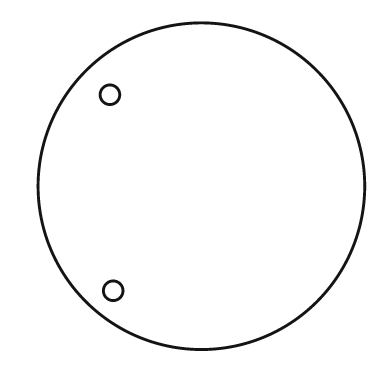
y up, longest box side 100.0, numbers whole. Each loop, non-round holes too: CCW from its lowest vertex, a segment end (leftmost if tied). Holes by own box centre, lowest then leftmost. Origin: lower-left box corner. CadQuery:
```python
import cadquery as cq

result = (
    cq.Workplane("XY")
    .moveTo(50.0, 50.0)
    .circle(50.0)
    .moveTo(23.0, 18.0)
    .circle(3.0)
    .moveTo(22.0, 78.0)
    .circle(3.0)
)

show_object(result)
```